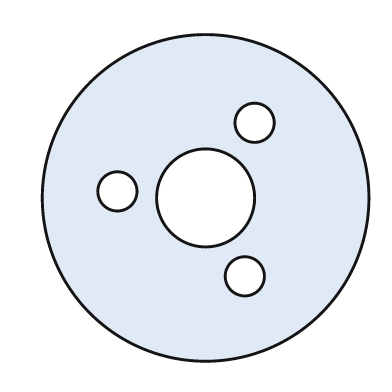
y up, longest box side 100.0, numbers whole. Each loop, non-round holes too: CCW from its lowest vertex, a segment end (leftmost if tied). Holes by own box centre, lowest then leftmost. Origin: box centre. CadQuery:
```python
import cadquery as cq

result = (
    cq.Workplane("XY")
    .moveTo(0.0, 0.0)
    .circle(50.0)
    .moveTo(12.0, -24.0)
    .circle(6.0)
    .moveTo(0.0, 0.0)
    .circle(15.0)
    .moveTo(-27.0, 2.0)
    .circle(6.0)
    .moveTo(15.0, 23.0)
    .circle(6.0)
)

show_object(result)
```